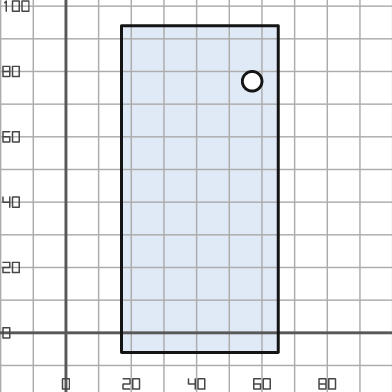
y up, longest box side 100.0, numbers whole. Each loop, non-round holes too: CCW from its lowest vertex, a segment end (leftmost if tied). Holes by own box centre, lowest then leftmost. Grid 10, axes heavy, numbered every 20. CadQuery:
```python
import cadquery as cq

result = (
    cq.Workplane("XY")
    .moveTo(17.0, -6.0)
    .lineTo(65.0, -6.0)
    .lineTo(65.0, 94.0)
    .lineTo(17.0, 94.0)
    .close()
    .moveTo(57.0, 77.0)
    .circle(3.0)
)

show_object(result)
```